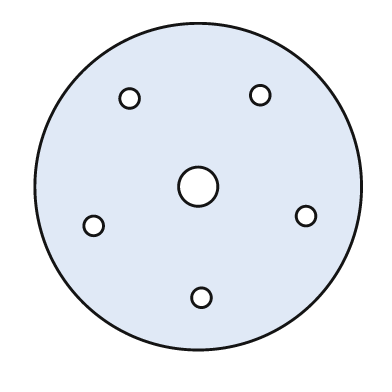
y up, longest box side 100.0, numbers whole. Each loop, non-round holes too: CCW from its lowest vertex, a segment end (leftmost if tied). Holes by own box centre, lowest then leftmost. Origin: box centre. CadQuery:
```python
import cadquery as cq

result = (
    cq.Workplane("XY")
    .moveTo(0.0, 0.0)
    .circle(50.0)
    .moveTo(1.0, -34.0)
    .circle(3.0)
    .moveTo(-32.0, -12.0)
    .circle(3.0)
    .moveTo(33.0, -9.0)
    .circle(3.0)
    .moveTo(0.0, 0.0)
    .circle(6.0)
    .moveTo(-21.0, 27.0)
    .circle(3.0)
    .moveTo(19.0, 28.0)
    .circle(3.0)
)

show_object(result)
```